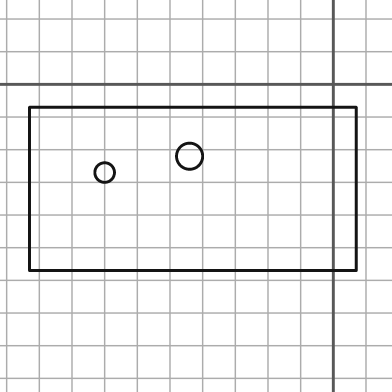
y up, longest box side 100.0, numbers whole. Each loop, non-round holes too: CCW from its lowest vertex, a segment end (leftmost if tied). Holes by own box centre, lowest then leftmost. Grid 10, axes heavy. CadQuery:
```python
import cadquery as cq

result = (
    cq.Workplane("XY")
    .moveTo(-93.0, -57.0)
    .lineTo(7.0, -57.0)
    .lineTo(7.0, -7.0)
    .lineTo(-93.0, -7.0)
    .close()
    .moveTo(-70.0, -27.0)
    .circle(3.0)
    .moveTo(-44.0, -22.0)
    .circle(4.0)
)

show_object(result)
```